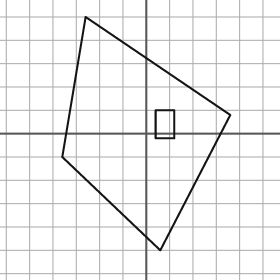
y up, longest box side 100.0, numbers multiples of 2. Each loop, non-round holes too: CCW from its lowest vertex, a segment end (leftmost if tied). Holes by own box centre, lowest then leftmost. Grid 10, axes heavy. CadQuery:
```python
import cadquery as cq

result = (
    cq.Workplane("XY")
    .moveTo(6.0, -50.0)
    .lineTo(36.0, 8.0)
    .lineTo(-26.0, 50.0)
    .lineTo(-36.0, -10.0)
    .close()
    .moveTo(4.0, -2.0)
    .lineTo(12.0, -2.0)
    .lineTo(12.0, 10.0)
    .lineTo(4.0, 10.0)
    .close()
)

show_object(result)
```